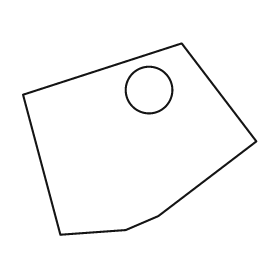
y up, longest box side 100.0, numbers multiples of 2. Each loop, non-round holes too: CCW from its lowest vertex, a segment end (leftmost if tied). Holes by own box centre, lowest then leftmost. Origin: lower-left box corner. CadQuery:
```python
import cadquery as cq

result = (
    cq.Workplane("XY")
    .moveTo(16.0, 0.0)
    .lineTo(44.0, 2.0)
    .lineTo(58.0, 8.0)
    .lineTo(100.0, 40.0)
    .lineTo(68.0, 82.0)
    .lineTo(0.0, 60.0)
    .close()
    .moveTo(54.0, 62.0)
    .circle(10.0)
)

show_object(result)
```